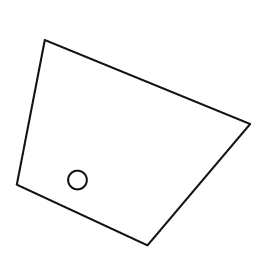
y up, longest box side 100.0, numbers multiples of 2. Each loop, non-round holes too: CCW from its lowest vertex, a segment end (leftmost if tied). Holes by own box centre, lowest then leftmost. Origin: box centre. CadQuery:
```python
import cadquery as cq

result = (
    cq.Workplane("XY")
    .moveTo(6.0, -44.0)
    .lineTo(50.0, 8.0)
    .lineTo(-38.0, 44.0)
    .lineTo(-50.0, -18.0)
    .close()
    .moveTo(-24.0, -16.0)
    .circle(4.0)
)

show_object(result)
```